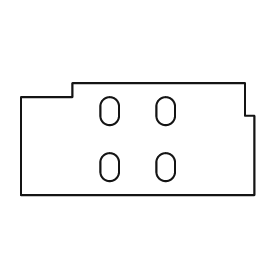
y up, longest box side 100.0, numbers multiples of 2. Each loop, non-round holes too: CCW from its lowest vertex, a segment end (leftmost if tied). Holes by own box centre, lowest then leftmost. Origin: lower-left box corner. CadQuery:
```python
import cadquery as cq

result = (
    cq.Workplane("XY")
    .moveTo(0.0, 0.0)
    .lineTo(100.0, 0.0)
    .lineTo(100.0, 34.0)
    .lineTo(96.0, 34.0)
    .lineTo(96.0, 48.0)
    .lineTo(22.0, 48.0)
    .lineTo(22.0, 42.0)
    .lineTo(0.0, 42.0)
    .close()
    .moveTo(34.0, 10.0)
    .threePointArc((38.0, 6.0), (42.0, 10.0))
    .lineTo(42.0, 14.0)
    .threePointArc((38.0, 18.0), (34.0, 14.0))
    .close()
    .moveTo(58.0, 10.0)
    .threePointArc((62.0, 6.0), (66.0, 10.0))
    .lineTo(66.0, 14.0)
    .threePointArc((62.0, 18.0), (58.0, 14.0))
    .close()
    .moveTo(34.0, 34.0)
    .threePointArc((38.0, 30.0), (42.0, 34.0))
    .lineTo(42.0, 38.0)
    .threePointArc((38.0, 42.0), (34.0, 38.0))
    .close()
    .moveTo(58.0, 34.0)
    .threePointArc((62.0, 30.0), (66.0, 34.0))
    .lineTo(66.0, 38.0)
    .threePointArc((62.0, 42.0), (58.0, 38.0))
    .close()
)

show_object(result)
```